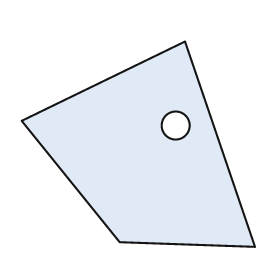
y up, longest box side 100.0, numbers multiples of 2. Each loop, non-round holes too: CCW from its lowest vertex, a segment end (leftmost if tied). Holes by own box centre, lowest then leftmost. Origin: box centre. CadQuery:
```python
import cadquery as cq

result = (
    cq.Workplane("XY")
    .moveTo(50.0, -44.0)
    .lineTo(20.0, 44.0)
    .lineTo(-50.0, 10.0)
    .lineTo(-8.0, -42.0)
    .close()
    .moveTo(16.0, 8.0)
    .circle(6.0)
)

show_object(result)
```